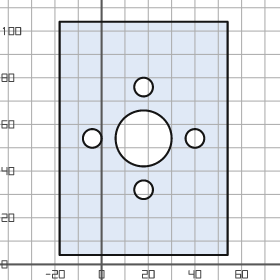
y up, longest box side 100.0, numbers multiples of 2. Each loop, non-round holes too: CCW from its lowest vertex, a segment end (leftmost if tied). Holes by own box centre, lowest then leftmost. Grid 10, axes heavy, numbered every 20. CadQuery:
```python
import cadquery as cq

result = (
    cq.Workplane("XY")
    .moveTo(-18.0, 4.0)
    .lineTo(54.0, 4.0)
    .lineTo(54.0, 104.0)
    .lineTo(-18.0, 104.0)
    .close()
    .moveTo(18.0, 32.0)
    .circle(4.0)
    .moveTo(-4.0, 54.0)
    .circle(4.0)
    .moveTo(18.0, 54.0)
    .circle(12.0)
    .moveTo(40.0, 54.0)
    .circle(4.0)
    .moveTo(18.0, 76.0)
    .circle(4.0)
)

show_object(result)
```